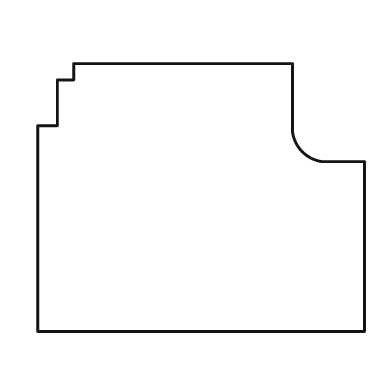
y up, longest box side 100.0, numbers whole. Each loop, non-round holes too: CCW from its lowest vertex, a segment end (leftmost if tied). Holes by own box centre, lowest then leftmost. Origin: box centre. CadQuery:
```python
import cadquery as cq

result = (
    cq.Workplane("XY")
    .moveTo(-50.0, -41.0)
    .lineTo(50.0, -41.0)
    .lineTo(50.0, 11.0)
    .lineTo(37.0, 11.0)
    .threePointArc((31.0, 14.0), (28.0, 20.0))
    .lineTo(28.0, 41.0)
    .lineTo(-39.0, 41.0)
    .lineTo(-39.0, 36.0)
    .lineTo(-44.0, 36.0)
    .lineTo(-44.0, 22.0)
    .lineTo(-50.0, 22.0)
    .close()
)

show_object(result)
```